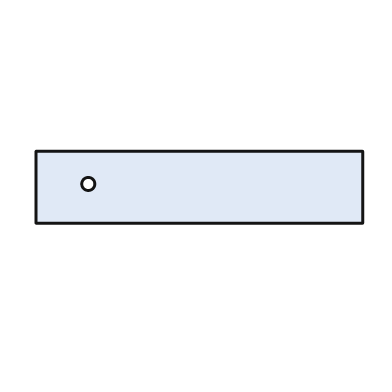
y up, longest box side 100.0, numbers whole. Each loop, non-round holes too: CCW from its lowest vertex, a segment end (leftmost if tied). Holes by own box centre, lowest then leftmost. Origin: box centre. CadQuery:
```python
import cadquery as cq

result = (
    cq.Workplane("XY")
    .moveTo(-50.0, -11.0)
    .lineTo(50.0, -11.0)
    .lineTo(50.0, 11.0)
    .lineTo(-50.0, 11.0)
    .close()
    .moveTo(-34.0, 1.0)
    .circle(2.0)
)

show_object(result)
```